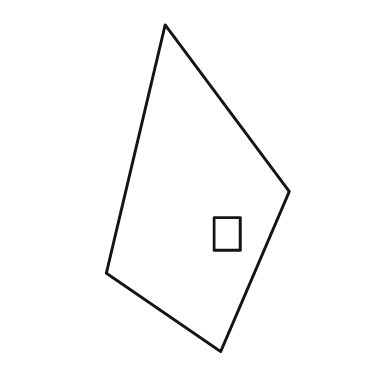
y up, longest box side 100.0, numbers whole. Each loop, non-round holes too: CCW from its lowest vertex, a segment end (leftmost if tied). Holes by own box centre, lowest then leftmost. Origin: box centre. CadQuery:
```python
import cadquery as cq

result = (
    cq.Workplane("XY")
    .moveTo(7.0, -50.0)
    .lineTo(28.0, -1.0)
    .lineTo(-10.0, 50.0)
    .lineTo(-28.0, -26.0)
    .close()
    .moveTo(5.0, -19.0)
    .lineTo(13.0, -19.0)
    .lineTo(13.0, -9.0)
    .lineTo(5.0, -9.0)
    .close()
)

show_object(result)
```